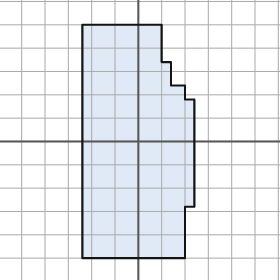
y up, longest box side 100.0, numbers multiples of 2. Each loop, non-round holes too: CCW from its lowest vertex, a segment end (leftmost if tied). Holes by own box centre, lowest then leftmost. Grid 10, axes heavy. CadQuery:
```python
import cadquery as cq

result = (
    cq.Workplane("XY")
    .moveTo(-24.0, -50.0)
    .lineTo(20.0, -50.0)
    .lineTo(20.0, -28.0)
    .lineTo(24.0, -28.0)
    .lineTo(24.0, 18.0)
    .lineTo(20.0, 18.0)
    .lineTo(20.0, 24.0)
    .lineTo(14.0, 24.0)
    .lineTo(14.0, 34.0)
    .lineTo(10.0, 34.0)
    .lineTo(10.0, 50.0)
    .lineTo(-24.0, 50.0)
    .close()
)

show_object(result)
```